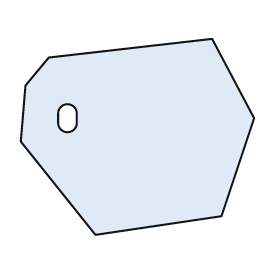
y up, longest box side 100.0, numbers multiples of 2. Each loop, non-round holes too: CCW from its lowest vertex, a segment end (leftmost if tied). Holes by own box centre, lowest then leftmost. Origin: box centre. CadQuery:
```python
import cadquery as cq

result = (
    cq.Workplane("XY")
    .moveTo(-18.0, -42.0)
    .lineTo(36.0, -34.0)
    .lineTo(50.0, 8.0)
    .lineTo(32.0, 42.0)
    .lineTo(-38.0, 34.0)
    .lineTo(-48.0, 22.0)
    .lineTo(-50.0, -2.0)
    .close()
    .moveTo(-34.0, 6.0)
    .threePointArc((-30.0, 2.0), (-26.0, 6.0))
    .lineTo(-26.0, 10.0)
    .threePointArc((-30.0, 14.0), (-34.0, 10.0))
    .close()
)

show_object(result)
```